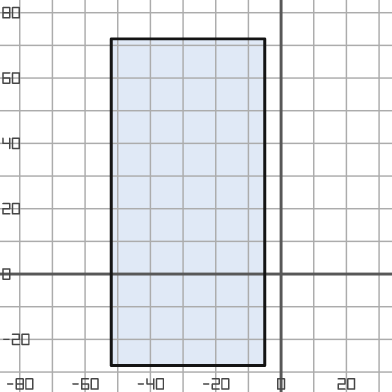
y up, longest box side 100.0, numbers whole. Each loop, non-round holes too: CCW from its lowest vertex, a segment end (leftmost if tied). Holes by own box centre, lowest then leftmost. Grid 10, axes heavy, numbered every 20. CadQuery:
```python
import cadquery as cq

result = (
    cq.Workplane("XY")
    .moveTo(-52.0, -28.0)
    .lineTo(-5.0, -28.0)
    .lineTo(-5.0, 72.0)
    .lineTo(-52.0, 72.0)
    .close()
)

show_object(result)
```